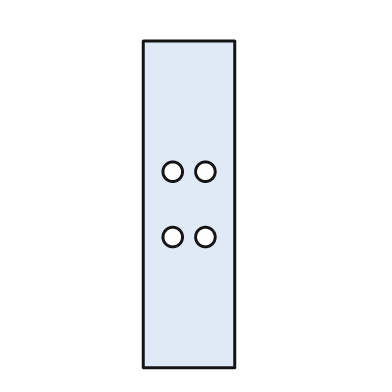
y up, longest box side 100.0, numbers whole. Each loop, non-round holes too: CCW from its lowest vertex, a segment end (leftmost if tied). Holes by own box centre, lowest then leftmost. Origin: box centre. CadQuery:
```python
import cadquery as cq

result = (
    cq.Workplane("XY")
    .moveTo(-14.0, -50.0)
    .lineTo(14.0, -50.0)
    .lineTo(14.0, 50.0)
    .lineTo(-14.0, 50.0)
    .close()
    .moveTo(-5.0, -10.0)
    .circle(3.0)
    .moveTo(5.0, -10.0)
    .circle(3.0)
    .moveTo(-5.0, 10.0)
    .circle(3.0)
    .moveTo(5.0, 10.0)
    .circle(3.0)
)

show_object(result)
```